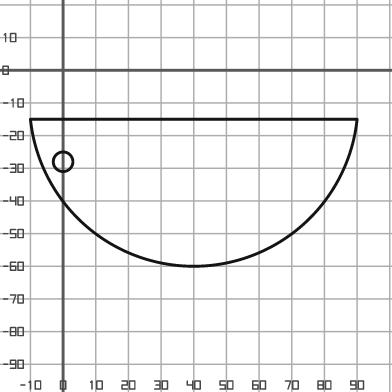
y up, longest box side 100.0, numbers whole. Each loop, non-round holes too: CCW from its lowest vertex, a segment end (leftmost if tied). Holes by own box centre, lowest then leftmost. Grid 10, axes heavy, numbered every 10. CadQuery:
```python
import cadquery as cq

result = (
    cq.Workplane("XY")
    .moveTo(-10.0, -15.0)
    .threePointArc((40.0, -60.0), (90.0, -15.0))
    .close()
    .moveTo(0.0, -28.0)
    .circle(3.0)
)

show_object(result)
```